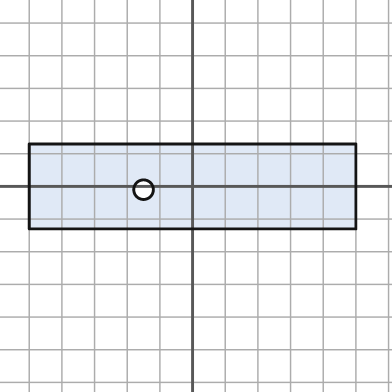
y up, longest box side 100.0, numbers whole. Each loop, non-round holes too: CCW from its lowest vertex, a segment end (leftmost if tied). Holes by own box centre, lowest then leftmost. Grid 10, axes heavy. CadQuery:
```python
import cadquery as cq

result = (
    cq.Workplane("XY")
    .moveTo(-50.0, -13.0)
    .lineTo(50.0, -13.0)
    .lineTo(50.0, 13.0)
    .lineTo(-50.0, 13.0)
    .close()
    .moveTo(-15.0, -1.0)
    .circle(3.0)
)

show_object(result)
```